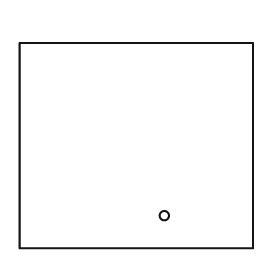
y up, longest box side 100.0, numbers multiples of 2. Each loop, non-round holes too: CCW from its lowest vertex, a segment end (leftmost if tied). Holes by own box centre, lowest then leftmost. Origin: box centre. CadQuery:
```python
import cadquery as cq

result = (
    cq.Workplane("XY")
    .moveTo(-50.0, -44.0)
    .lineTo(50.0, -44.0)
    .lineTo(50.0, 44.0)
    .lineTo(-50.0, 44.0)
    .close()
    .moveTo(12.0, -30.0)
    .circle(2.0)
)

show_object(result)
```